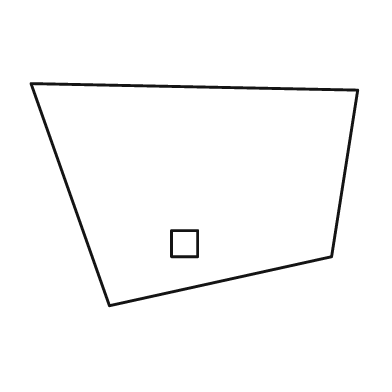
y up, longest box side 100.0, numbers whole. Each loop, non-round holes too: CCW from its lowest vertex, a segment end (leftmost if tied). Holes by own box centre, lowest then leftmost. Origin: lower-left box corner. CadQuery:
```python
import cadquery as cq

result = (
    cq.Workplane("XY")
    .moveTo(24.0, 0.0)
    .lineTo(92.0, 15.0)
    .lineTo(100.0, 66.0)
    .lineTo(0.0, 68.0)
    .close()
    .moveTo(43.0, 15.0)
    .lineTo(51.0, 15.0)
    .lineTo(51.0, 23.0)
    .lineTo(43.0, 23.0)
    .close()
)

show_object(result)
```